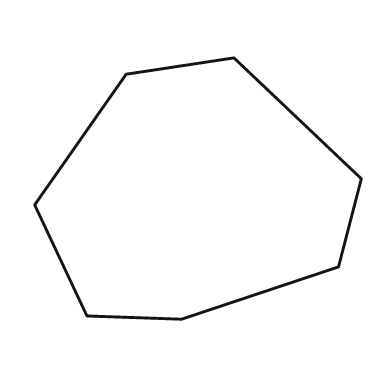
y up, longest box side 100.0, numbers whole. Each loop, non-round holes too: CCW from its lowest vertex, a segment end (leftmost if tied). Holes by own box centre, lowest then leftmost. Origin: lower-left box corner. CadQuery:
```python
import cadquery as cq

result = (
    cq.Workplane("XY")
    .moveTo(45.0, 0.0)
    .lineTo(93.0, 16.0)
    .lineTo(100.0, 43.0)
    .lineTo(61.0, 80.0)
    .lineTo(28.0, 75.0)
    .lineTo(0.0, 35.0)
    .lineTo(16.0, 1.0)
    .close()
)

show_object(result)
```